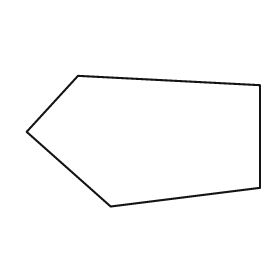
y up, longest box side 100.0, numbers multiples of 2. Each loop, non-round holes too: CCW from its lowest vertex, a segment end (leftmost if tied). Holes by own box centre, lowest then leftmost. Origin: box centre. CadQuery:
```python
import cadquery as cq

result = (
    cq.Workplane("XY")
    .moveTo(-14.0, -28.0)
    .lineTo(50.0, -20.0)
    .lineTo(50.0, 24.0)
    .lineTo(-28.0, 28.0)
    .lineTo(-50.0, 4.0)
    .close()
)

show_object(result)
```